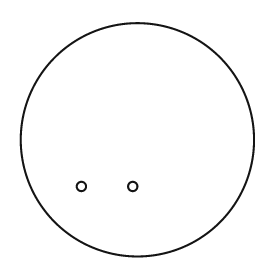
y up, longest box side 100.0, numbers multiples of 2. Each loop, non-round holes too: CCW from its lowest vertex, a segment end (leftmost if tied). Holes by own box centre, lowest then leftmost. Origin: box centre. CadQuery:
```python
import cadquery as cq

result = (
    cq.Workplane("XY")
    .moveTo(0.0, 0.0)
    .circle(50.0)
    .moveTo(-24.0, -20.0)
    .circle(2.0)
    .moveTo(-2.0, -20.0)
    .circle(2.0)
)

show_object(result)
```